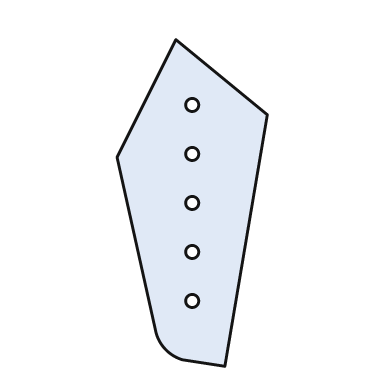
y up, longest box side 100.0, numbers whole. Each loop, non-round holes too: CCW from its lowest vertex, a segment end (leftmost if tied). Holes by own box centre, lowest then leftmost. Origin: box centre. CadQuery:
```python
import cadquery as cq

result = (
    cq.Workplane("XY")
    .moveTo(10.0, -50.0)
    .lineTo(23.0, 27.0)
    .lineTo(-5.0, 50.0)
    .lineTo(-23.0, 14.0)
    .lineTo(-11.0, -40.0)
    .threePointArc((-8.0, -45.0), (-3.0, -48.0))
    .close()
    .moveTo(0.0, -30.0)
    .circle(2.0)
    .moveTo(0.0, -15.0)
    .circle(2.0)
    .moveTo(0.0, 0.0)
    .circle(2.0)
    .moveTo(0.0, 15.0)
    .circle(2.0)
    .moveTo(0.0, 30.0)
    .circle(2.0)
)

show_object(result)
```